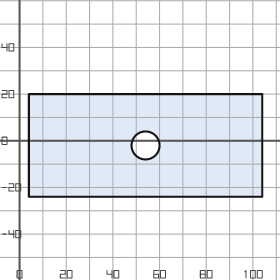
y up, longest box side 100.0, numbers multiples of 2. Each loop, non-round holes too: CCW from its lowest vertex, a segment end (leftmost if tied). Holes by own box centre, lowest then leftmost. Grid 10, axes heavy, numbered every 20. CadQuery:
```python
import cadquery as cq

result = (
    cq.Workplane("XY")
    .moveTo(4.0, -24.0)
    .lineTo(104.0, -24.0)
    .lineTo(104.0, 20.0)
    .lineTo(4.0, 20.0)
    .close()
    .moveTo(54.0, -2.0)
    .circle(6.0)
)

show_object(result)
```